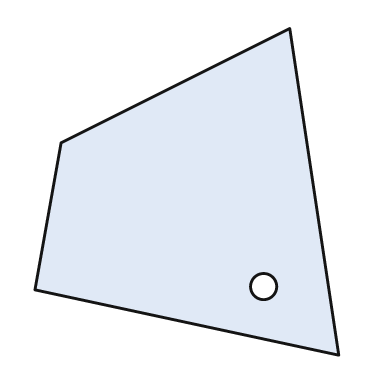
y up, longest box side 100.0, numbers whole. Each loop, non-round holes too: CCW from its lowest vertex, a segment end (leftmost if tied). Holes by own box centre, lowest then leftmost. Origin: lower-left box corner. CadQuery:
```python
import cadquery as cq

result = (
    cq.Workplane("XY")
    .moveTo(93.0, 0.0)
    .lineTo(78.0, 100.0)
    .lineTo(8.0, 65.0)
    .lineTo(0.0, 20.0)
    .close()
    .moveTo(70.0, 21.0)
    .circle(4.0)
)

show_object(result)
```